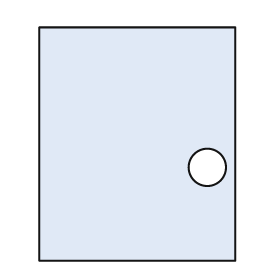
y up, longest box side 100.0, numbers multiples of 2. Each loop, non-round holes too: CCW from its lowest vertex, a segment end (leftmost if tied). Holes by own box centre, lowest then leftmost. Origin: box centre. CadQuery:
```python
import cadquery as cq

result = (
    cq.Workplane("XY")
    .moveTo(-42.0, -50.0)
    .lineTo(42.0, -50.0)
    .lineTo(42.0, 50.0)
    .lineTo(-42.0, 50.0)
    .close()
    .moveTo(30.0, -10.0)
    .circle(8.0)
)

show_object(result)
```